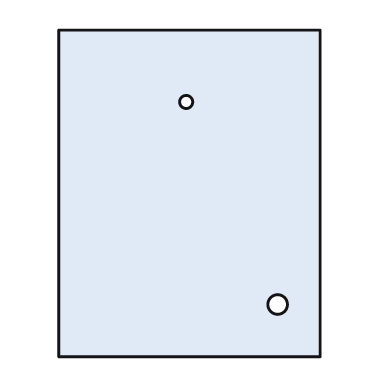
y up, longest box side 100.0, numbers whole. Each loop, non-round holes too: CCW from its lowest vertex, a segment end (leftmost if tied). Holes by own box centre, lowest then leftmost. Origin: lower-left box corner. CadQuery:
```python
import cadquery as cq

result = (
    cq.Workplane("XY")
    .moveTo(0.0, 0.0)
    .lineTo(80.0, 0.0)
    .lineTo(80.0, 100.0)
    .lineTo(0.0, 100.0)
    .close()
    .moveTo(67.0, 16.0)
    .circle(3.0)
    .moveTo(39.0, 78.0)
    .circle(2.0)
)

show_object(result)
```